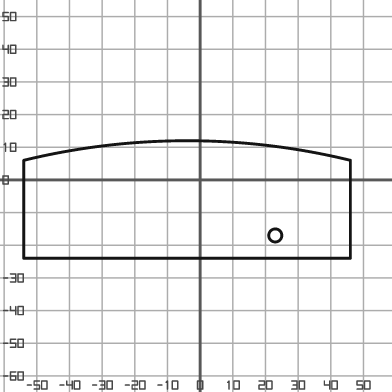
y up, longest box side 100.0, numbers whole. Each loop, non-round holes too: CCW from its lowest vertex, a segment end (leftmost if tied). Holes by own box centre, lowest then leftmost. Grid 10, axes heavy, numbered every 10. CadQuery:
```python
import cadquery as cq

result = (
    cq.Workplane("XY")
    .moveTo(-54.0, -24.0)
    .lineTo(46.0, -24.0)
    .lineTo(46.0, 6.0)
    .threePointArc((-4.0, 12.0), (-54.0, 6.0))
    .close()
    .moveTo(23.0, -17.0)
    .circle(2.0)
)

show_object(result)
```